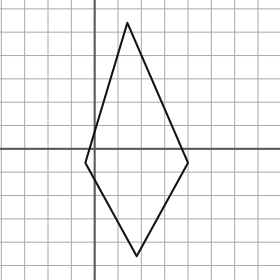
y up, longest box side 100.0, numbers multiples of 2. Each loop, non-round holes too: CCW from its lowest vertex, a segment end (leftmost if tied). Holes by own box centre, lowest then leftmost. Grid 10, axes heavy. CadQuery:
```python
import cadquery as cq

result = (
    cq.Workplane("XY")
    .moveTo(18.0, -46.0)
    .lineTo(40.0, -6.0)
    .lineTo(14.0, 54.0)
    .lineTo(-4.0, -6.0)
    .close()
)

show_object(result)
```